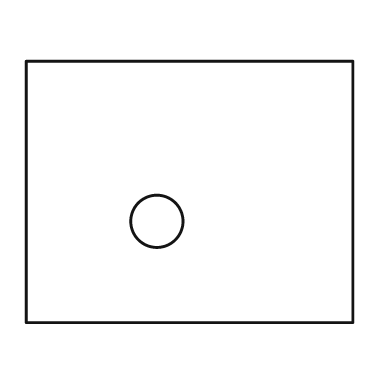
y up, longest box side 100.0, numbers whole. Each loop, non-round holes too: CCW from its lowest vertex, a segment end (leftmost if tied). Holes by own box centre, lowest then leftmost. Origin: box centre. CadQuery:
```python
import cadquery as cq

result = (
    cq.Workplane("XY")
    .moveTo(-50.0, -40.0)
    .lineTo(50.0, -40.0)
    .lineTo(50.0, 40.0)
    .lineTo(-50.0, 40.0)
    .close()
    .moveTo(-10.0, -9.0)
    .circle(8.0)
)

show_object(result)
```